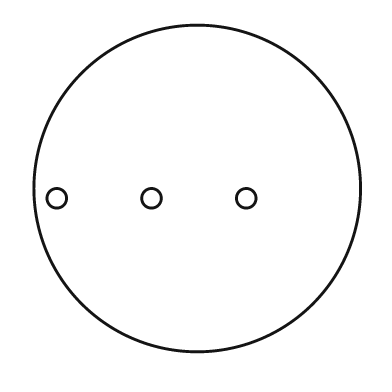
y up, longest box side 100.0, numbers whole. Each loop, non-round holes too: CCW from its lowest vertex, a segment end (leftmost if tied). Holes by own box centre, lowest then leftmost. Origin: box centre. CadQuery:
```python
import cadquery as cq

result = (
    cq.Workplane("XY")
    .moveTo(0.0, 0.0)
    .circle(50.0)
    .moveTo(-43.0, -3.0)
    .circle(3.0)
    .moveTo(-14.0, -3.0)
    .circle(3.0)
    .moveTo(15.0, -3.0)
    .circle(3.0)
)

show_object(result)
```